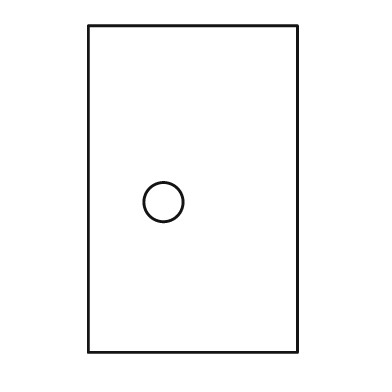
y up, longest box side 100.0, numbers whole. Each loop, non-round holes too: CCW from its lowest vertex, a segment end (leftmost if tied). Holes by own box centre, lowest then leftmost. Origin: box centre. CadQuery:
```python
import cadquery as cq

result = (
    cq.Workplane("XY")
    .moveTo(-32.0, -50.0)
    .lineTo(32.0, -50.0)
    .lineTo(32.0, 50.0)
    .lineTo(-32.0, 50.0)
    .close()
    .moveTo(-9.0, -4.0)
    .circle(6.0)
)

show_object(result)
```